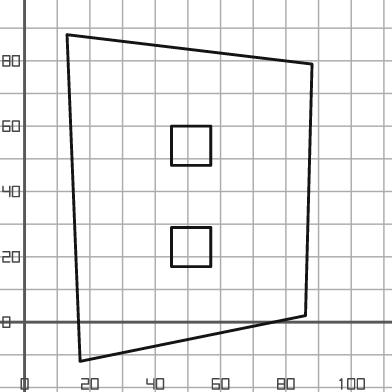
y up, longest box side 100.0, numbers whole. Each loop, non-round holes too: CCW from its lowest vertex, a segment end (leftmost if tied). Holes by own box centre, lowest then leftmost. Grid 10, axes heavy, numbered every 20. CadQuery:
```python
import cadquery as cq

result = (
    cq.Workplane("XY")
    .moveTo(17.0, -12.0)
    .lineTo(86.0, 2.0)
    .lineTo(88.0, 79.0)
    .lineTo(13.0, 88.0)
    .close()
    .moveTo(45.0, 17.0)
    .lineTo(57.0, 17.0)
    .lineTo(57.0, 29.0)
    .lineTo(45.0, 29.0)
    .close()
    .moveTo(45.0, 48.0)
    .lineTo(57.0, 48.0)
    .lineTo(57.0, 60.0)
    .lineTo(45.0, 60.0)
    .close()
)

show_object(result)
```